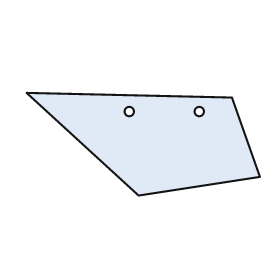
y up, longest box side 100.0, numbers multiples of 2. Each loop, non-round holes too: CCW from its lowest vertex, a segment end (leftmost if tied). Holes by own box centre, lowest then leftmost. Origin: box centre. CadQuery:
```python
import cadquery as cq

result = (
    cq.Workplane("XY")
    .moveTo(-2.0, -22.0)
    .lineTo(50.0, -14.0)
    .lineTo(38.0, 20.0)
    .lineTo(-50.0, 22.0)
    .close()
    .moveTo(-6.0, 14.0)
    .circle(2.0)
    .moveTo(24.0, 14.0)
    .circle(2.0)
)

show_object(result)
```